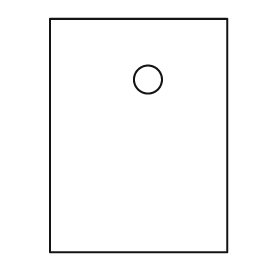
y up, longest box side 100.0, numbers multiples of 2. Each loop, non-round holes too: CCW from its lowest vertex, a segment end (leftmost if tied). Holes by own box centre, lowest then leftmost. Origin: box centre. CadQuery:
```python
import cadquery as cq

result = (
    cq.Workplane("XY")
    .moveTo(-38.0, -50.0)
    .lineTo(38.0, -50.0)
    .lineTo(38.0, 50.0)
    .lineTo(-38.0, 50.0)
    .close()
    .moveTo(4.0, 24.0)
    .circle(6.0)
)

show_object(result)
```